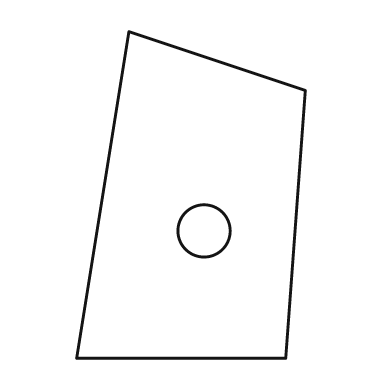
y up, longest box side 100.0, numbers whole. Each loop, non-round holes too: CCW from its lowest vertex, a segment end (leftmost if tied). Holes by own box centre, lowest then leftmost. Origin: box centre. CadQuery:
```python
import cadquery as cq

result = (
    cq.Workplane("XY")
    .moveTo(-35.0, -50.0)
    .lineTo(29.0, -50.0)
    .lineTo(35.0, 32.0)
    .lineTo(-19.0, 50.0)
    .close()
    .moveTo(4.0, -11.0)
    .circle(8.0)
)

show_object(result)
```